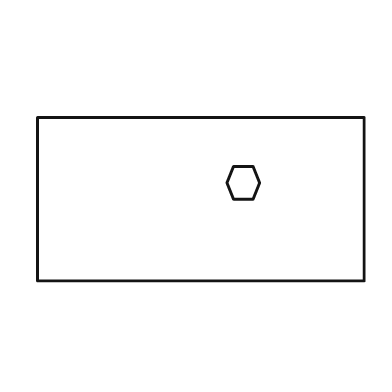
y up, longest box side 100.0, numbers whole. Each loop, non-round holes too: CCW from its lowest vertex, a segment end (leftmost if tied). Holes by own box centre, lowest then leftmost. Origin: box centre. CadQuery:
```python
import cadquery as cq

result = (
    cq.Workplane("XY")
    .moveTo(-50.0, -25.0)
    .lineTo(50.0, -25.0)
    .lineTo(50.0, 25.0)
    .lineTo(-50.0, 25.0)
    .close()
    .moveTo(10.0, 0.0)
    .lineTo(16.0, 0.0)
    .lineTo(18.0, 5.0)
    .lineTo(16.0, 10.0)
    .lineTo(10.0, 10.0)
    .lineTo(8.0, 5.0)
    .close()
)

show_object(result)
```